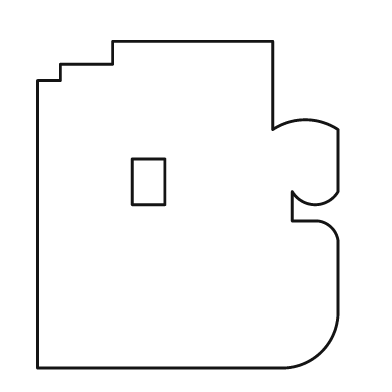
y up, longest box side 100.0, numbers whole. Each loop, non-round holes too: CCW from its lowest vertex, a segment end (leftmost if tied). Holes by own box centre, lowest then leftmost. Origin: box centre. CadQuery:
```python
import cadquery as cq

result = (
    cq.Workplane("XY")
    .moveTo(-46.0, -50.0)
    .lineTo(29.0, -50.0)
    .threePointArc((41.0, -45.0), (46.0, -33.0))
    .lineTo(46.0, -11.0)
    .threePointArc((44.0, -7.0), (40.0, -5.0))
    .lineTo(32.0, -5.0)
    .lineTo(32.0, 4.0)
    .threePointArc((39.0, 0.0), (46.0, 4.0))
    .lineTo(46.0, 23.0)
    .threePointArc((36.0, 26.0), (26.0, 23.0))
    .lineTo(26.0, 50.0)
    .lineTo(-23.0, 50.0)
    .lineTo(-23.0, 43.0)
    .lineTo(-39.0, 43.0)
    .lineTo(-39.0, 38.0)
    .lineTo(-46.0, 38.0)
    .close()
    .moveTo(-17.0, 0.0)
    .lineTo(-7.0, 0.0)
    .lineTo(-7.0, 14.0)
    .lineTo(-17.0, 14.0)
    .close()
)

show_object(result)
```